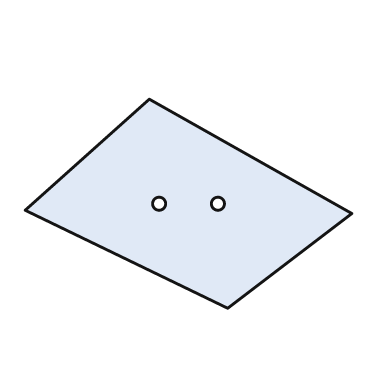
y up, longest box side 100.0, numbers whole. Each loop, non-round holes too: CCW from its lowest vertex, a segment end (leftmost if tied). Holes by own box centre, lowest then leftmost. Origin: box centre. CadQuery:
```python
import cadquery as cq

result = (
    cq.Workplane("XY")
    .moveTo(12.0, -32.0)
    .lineTo(50.0, -3.0)
    .lineTo(-12.0, 32.0)
    .lineTo(-50.0, -2.0)
    .close()
    .moveTo(-9.0, 0.0)
    .circle(2.0)
    .moveTo(9.0, 0.0)
    .circle(2.0)
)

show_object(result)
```